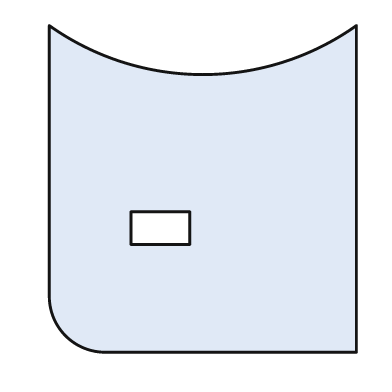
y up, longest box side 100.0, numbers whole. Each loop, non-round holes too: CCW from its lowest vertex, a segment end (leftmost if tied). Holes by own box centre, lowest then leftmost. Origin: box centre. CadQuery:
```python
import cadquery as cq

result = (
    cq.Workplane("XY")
    .moveTo(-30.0, -50.0)
    .lineTo(47.0, -50.0)
    .lineTo(47.0, 50.0)
    .threePointArc((0.0, 35.0), (-47.0, 50.0))
    .lineTo(-47.0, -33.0)
    .threePointArc((-42.0, -45.0), (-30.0, -50.0))
    .close()
    .moveTo(-22.0, -17.0)
    .lineTo(-4.0, -17.0)
    .lineTo(-4.0, -7.0)
    .lineTo(-22.0, -7.0)
    .close()
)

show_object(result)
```